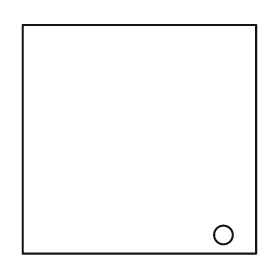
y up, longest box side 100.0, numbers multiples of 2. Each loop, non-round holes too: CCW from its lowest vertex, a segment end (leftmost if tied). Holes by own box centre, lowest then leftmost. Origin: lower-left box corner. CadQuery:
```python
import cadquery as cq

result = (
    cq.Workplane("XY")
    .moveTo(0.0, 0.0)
    .lineTo(100.0, 0.0)
    .lineTo(100.0, 98.0)
    .lineTo(0.0, 98.0)
    .close()
    .moveTo(86.0, 8.0)
    .circle(4.0)
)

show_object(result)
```